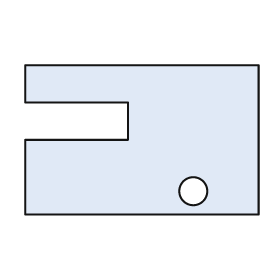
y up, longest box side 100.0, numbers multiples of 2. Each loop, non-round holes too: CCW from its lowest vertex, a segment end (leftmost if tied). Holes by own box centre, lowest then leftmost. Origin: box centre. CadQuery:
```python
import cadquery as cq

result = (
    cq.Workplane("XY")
    .moveTo(-50.0, -32.0)
    .lineTo(50.0, -32.0)
    .lineTo(50.0, 32.0)
    .lineTo(-50.0, 32.0)
    .lineTo(-50.0, 16.0)
    .lineTo(-6.0, 16.0)
    .lineTo(-6.0, 0.0)
    .lineTo(-50.0, 0.0)
    .close()
    .moveTo(22.0, -22.0)
    .circle(6.0)
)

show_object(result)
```